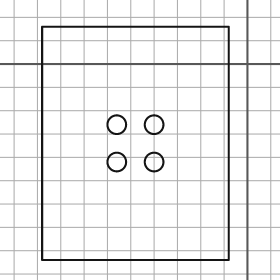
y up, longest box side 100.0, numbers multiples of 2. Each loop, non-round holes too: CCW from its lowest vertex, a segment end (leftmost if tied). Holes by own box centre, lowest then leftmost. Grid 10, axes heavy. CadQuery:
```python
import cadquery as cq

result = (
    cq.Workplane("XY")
    .moveTo(-88.0, -84.0)
    .lineTo(-8.0, -84.0)
    .lineTo(-8.0, 16.0)
    .lineTo(-88.0, 16.0)
    .close()
    .moveTo(-56.0, -42.0)
    .circle(4.0)
    .moveTo(-40.0, -42.0)
    .circle(4.0)
    .moveTo(-56.0, -26.0)
    .circle(4.0)
    .moveTo(-40.0, -26.0)
    .circle(4.0)
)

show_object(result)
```